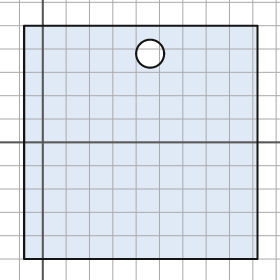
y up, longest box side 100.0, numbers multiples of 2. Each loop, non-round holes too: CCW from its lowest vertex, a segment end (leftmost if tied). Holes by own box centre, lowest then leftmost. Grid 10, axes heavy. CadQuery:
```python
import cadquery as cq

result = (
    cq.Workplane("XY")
    .moveTo(-8.0, -50.0)
    .lineTo(92.0, -50.0)
    .lineTo(92.0, 50.0)
    .lineTo(-8.0, 50.0)
    .close()
    .moveTo(46.0, 38.0)
    .circle(6.0)
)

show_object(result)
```